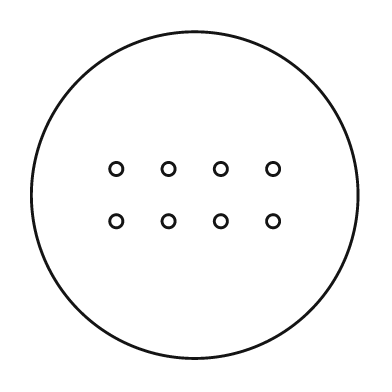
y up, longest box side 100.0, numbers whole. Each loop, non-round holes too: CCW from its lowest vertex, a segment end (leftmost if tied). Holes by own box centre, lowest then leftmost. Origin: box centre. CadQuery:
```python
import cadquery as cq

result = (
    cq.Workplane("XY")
    .moveTo(0.0, 0.0)
    .circle(50.0)
    .moveTo(-24.0, -8.0)
    .circle(2.0)
    .moveTo(-8.0, -8.0)
    .circle(2.0)
    .moveTo(8.0, -8.0)
    .circle(2.0)
    .moveTo(24.0, -8.0)
    .circle(2.0)
    .moveTo(-24.0, 8.0)
    .circle(2.0)
    .moveTo(-8.0, 8.0)
    .circle(2.0)
    .moveTo(8.0, 8.0)
    .circle(2.0)
    .moveTo(24.0, 8.0)
    .circle(2.0)
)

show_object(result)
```